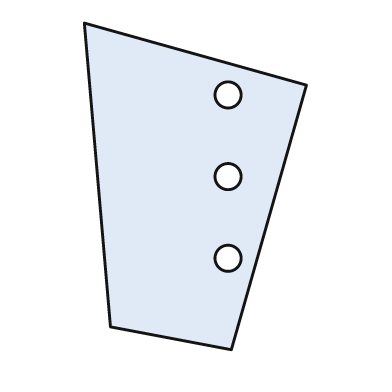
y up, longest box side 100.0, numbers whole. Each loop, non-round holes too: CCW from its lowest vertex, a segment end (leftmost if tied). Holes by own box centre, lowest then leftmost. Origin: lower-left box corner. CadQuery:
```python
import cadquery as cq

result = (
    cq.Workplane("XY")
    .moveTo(45.0, 0.0)
    .lineTo(68.0, 81.0)
    .lineTo(0.0, 100.0)
    .lineTo(8.0, 7.0)
    .close()
    .moveTo(44.0, 28.0)
    .circle(4.0)
    .moveTo(44.0, 53.0)
    .circle(4.0)
    .moveTo(44.0, 78.0)
    .circle(4.0)
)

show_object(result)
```